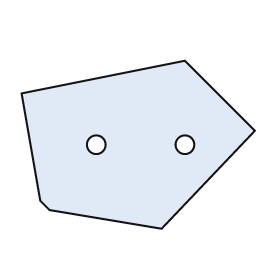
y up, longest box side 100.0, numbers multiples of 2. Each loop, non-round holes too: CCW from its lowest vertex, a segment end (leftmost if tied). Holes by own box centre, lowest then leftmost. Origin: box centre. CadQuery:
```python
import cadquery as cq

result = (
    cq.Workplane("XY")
    .moveTo(10.0, -36.0)
    .lineTo(50.0, 6.0)
    .lineTo(20.0, 36.0)
    .lineTo(-50.0, 22.0)
    .lineTo(-42.0, -24.0)
    .lineTo(-38.0, -28.0)
    .close()
    .moveTo(-18.0, 0.0)
    .circle(4.0)
    .moveTo(20.0, 0.0)
    .circle(4.0)
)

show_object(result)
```